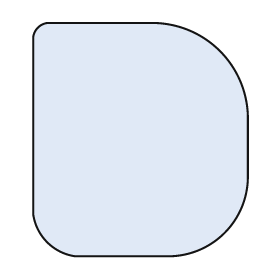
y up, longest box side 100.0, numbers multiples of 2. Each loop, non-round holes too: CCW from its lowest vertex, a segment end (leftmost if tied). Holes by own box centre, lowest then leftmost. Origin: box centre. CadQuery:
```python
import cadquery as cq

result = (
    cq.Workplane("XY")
    .moveTo(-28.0, -50.0)
    .lineTo(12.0, -50.0)
    .threePointArc((36.0, -40.0), (46.0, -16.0))
    .lineTo(46.0, 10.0)
    .threePointArc((34.0, 38.0), (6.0, 50.0))
    .lineTo(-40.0, 50.0)
    .threePointArc((-44.0, 48.0), (-46.0, 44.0))
    .lineTo(-46.0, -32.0)
    .threePointArc((-40.0, -44.0), (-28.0, -50.0))
    .close()
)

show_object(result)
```